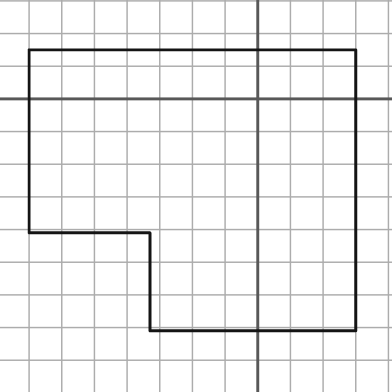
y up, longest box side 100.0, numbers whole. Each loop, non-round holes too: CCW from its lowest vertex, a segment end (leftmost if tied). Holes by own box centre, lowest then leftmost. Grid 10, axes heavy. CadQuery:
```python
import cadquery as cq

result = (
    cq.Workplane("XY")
    .moveTo(-33.0, -71.0)
    .lineTo(30.0, -71.0)
    .lineTo(30.0, 15.0)
    .lineTo(-70.0, 15.0)
    .lineTo(-70.0, -41.0)
    .lineTo(-33.0, -41.0)
    .close()
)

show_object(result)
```